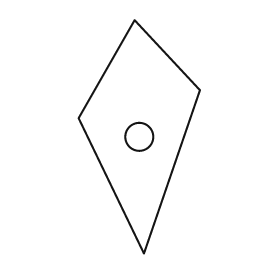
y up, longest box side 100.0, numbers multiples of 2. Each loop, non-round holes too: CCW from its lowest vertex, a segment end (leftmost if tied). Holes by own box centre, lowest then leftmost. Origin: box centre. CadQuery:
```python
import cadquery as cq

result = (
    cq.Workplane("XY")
    .moveTo(2.0, -50.0)
    .lineTo(26.0, 20.0)
    .lineTo(-2.0, 50.0)
    .lineTo(-26.0, 8.0)
    .close()
    .moveTo(0.0, 0.0)
    .circle(6.0)
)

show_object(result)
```